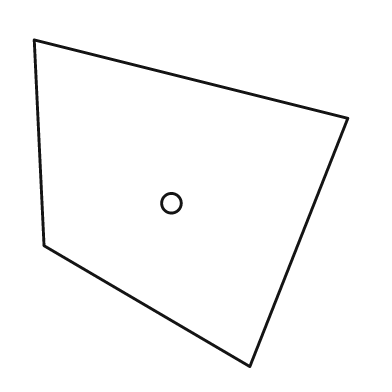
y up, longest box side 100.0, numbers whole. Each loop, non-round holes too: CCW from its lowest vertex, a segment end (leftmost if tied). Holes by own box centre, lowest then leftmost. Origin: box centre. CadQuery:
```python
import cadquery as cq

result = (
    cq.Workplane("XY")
    .moveTo(18.0, -50.0)
    .lineTo(48.0, 26.0)
    .lineTo(-48.0, 50.0)
    .lineTo(-45.0, -13.0)
    .close()
    .moveTo(-6.0, 0.0)
    .circle(3.0)
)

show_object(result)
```